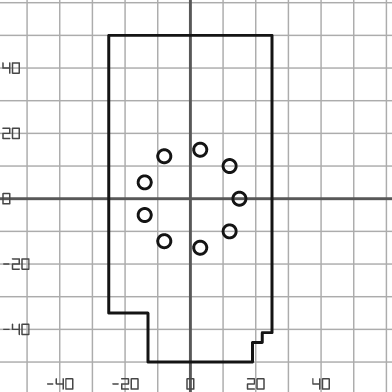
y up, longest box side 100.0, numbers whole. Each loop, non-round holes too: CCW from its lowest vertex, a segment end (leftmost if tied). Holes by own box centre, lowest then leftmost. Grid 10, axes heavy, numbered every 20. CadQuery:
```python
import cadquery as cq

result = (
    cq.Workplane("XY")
    .moveTo(-13.0, -50.0)
    .lineTo(19.0, -50.0)
    .lineTo(19.0, -44.0)
    .lineTo(22.0, -44.0)
    .lineTo(22.0, -41.0)
    .lineTo(25.0, -41.0)
    .lineTo(25.0, 50.0)
    .lineTo(-25.0, 50.0)
    .lineTo(-25.0, -35.0)
    .lineTo(-13.0, -35.0)
    .close()
    .moveTo(3.0, -15.0)
    .circle(2.0)
    .moveTo(-8.0, -13.0)
    .circle(2.0)
    .moveTo(12.0, -10.0)
    .circle(2.0)
    .moveTo(-14.0, -5.0)
    .circle(2.0)
    .moveTo(15.0, 0.0)
    .circle(2.0)
    .moveTo(-14.0, 5.0)
    .circle(2.0)
    .moveTo(12.0, 10.0)
    .circle(2.0)
    .moveTo(-8.0, 13.0)
    .circle(2.0)
    .moveTo(3.0, 15.0)
    .circle(2.0)
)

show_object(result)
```